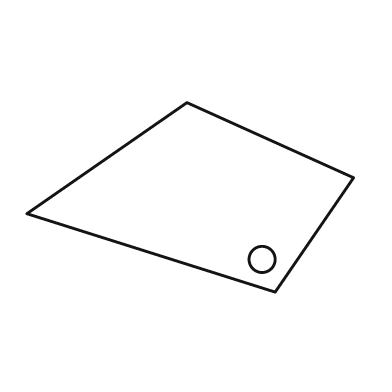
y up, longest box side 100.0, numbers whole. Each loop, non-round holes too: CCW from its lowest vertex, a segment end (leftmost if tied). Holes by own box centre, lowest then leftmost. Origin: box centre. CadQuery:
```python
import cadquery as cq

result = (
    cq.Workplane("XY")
    .moveTo(26.0, -29.0)
    .lineTo(50.0, 6.0)
    .lineTo(-1.0, 29.0)
    .lineTo(-50.0, -5.0)
    .close()
    .moveTo(22.0, -19.0)
    .circle(4.0)
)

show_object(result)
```